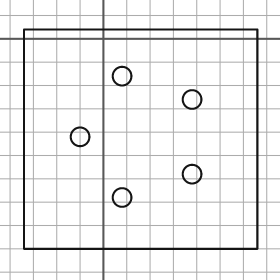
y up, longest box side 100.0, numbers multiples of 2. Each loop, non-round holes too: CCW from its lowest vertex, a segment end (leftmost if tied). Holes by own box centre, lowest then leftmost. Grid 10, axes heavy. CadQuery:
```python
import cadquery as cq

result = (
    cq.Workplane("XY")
    .moveTo(-34.0, -90.0)
    .lineTo(66.0, -90.0)
    .lineTo(66.0, 4.0)
    .lineTo(-34.0, 4.0)
    .close()
    .moveTo(8.0, -68.0)
    .circle(4.0)
    .moveTo(38.0, -58.0)
    .circle(4.0)
    .moveTo(-10.0, -42.0)
    .circle(4.0)
    .moveTo(38.0, -26.0)
    .circle(4.0)
    .moveTo(8.0, -16.0)
    .circle(4.0)
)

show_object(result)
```